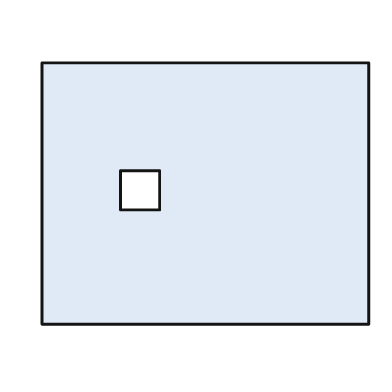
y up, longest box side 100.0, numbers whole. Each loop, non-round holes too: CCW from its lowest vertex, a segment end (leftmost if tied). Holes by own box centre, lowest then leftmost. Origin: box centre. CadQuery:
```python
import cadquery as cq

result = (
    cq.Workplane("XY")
    .moveTo(-50.0, -40.0)
    .lineTo(50.0, -40.0)
    .lineTo(50.0, 40.0)
    .lineTo(-50.0, 40.0)
    .close()
    .moveTo(-26.0, -5.0)
    .lineTo(-14.0, -5.0)
    .lineTo(-14.0, 7.0)
    .lineTo(-26.0, 7.0)
    .close()
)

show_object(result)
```